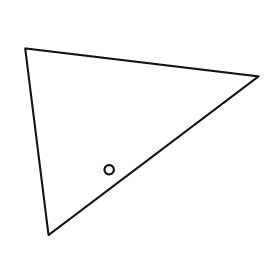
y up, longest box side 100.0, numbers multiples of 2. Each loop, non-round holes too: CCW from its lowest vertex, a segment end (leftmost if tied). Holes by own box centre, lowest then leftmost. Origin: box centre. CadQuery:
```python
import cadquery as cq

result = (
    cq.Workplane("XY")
    .moveTo(-40.0, -40.0)
    .lineTo(50.0, 28.0)
    .lineTo(-50.0, 40.0)
    .close()
    .moveTo(-14.0, -12.0)
    .circle(2.0)
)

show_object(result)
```